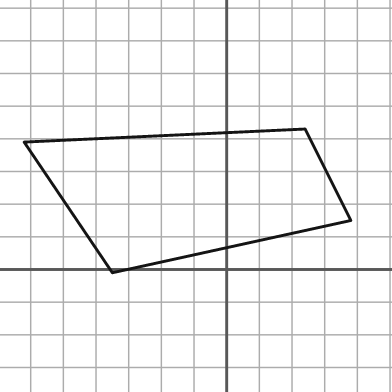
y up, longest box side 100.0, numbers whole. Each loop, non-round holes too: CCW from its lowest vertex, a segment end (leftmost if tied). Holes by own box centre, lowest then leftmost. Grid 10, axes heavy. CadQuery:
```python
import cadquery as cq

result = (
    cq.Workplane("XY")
    .moveTo(-35.0, -1.0)
    .lineTo(38.0, 15.0)
    .lineTo(24.0, 43.0)
    .lineTo(-62.0, 39.0)
    .close()
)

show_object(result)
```